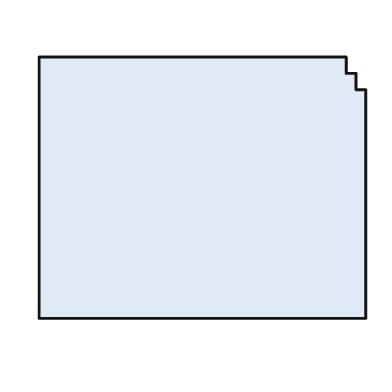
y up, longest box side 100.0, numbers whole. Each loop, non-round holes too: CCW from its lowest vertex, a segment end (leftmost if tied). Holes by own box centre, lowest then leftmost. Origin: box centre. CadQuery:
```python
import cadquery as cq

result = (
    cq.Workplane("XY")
    .moveTo(-50.0, -40.0)
    .lineTo(50.0, -40.0)
    .lineTo(50.0, 30.0)
    .lineTo(47.0, 30.0)
    .lineTo(47.0, 35.0)
    .lineTo(44.0, 35.0)
    .lineTo(44.0, 40.0)
    .lineTo(-50.0, 40.0)
    .close()
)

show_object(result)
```